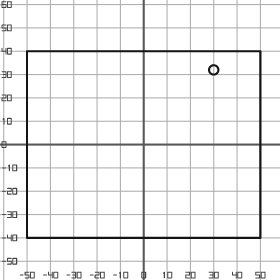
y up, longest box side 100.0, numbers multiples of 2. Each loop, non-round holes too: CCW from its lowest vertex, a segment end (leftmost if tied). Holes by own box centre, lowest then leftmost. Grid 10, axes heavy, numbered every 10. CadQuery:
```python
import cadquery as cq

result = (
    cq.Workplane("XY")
    .moveTo(-50.0, -40.0)
    .lineTo(50.0, -40.0)
    .lineTo(50.0, 40.0)
    .lineTo(-50.0, 40.0)
    .close()
    .moveTo(30.0, 32.0)
    .circle(2.0)
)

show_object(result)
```